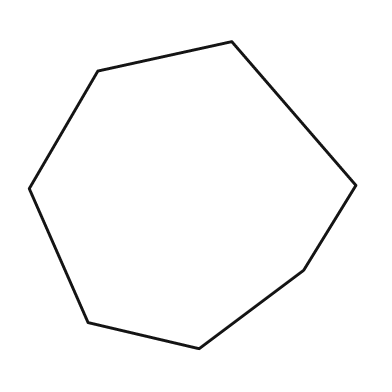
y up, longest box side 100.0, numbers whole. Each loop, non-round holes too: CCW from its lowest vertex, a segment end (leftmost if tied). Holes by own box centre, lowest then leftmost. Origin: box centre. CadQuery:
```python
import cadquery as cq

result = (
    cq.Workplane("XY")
    .moveTo(2.0, -47.0)
    .lineTo(34.0, -23.0)
    .lineTo(50.0, 3.0)
    .lineTo(12.0, 47.0)
    .lineTo(-29.0, 38.0)
    .lineTo(-50.0, 2.0)
    .lineTo(-32.0, -39.0)
    .close()
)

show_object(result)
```